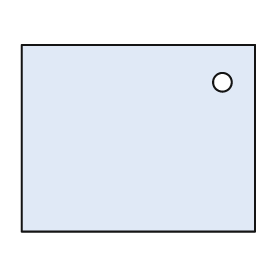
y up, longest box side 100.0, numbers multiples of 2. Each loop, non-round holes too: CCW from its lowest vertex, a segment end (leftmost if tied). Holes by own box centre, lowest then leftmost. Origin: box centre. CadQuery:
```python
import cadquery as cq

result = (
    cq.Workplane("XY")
    .moveTo(-50.0, -40.0)
    .lineTo(50.0, -40.0)
    .lineTo(50.0, 40.0)
    .lineTo(-50.0, 40.0)
    .close()
    .moveTo(36.0, 24.0)
    .circle(4.0)
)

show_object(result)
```